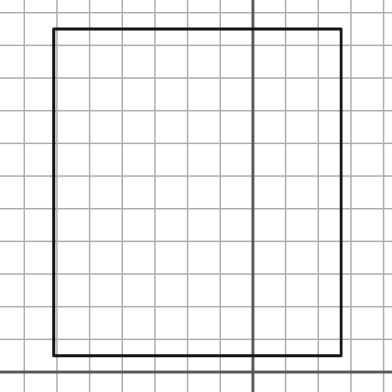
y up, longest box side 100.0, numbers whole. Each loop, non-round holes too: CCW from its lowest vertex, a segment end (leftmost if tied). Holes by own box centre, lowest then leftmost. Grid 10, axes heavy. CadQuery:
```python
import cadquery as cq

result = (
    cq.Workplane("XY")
    .moveTo(-61.0, 5.0)
    .lineTo(27.0, 5.0)
    .lineTo(27.0, 105.0)
    .lineTo(-61.0, 105.0)
    .close()
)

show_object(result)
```